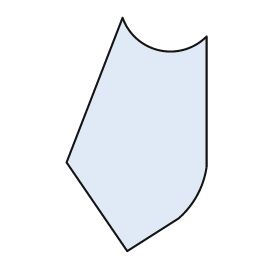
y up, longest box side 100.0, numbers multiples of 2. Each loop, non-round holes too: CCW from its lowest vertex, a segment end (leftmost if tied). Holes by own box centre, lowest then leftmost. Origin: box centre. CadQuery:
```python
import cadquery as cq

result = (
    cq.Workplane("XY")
    .moveTo(-4.0, -50.0)
    .lineTo(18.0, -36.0)
    .threePointArc((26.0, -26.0), (30.0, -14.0))
    .lineTo(30.0, 42.0)
    .threePointArc((10.0, 36.0), (-6.0, 50.0))
    .lineTo(-30.0, -12.0)
    .close()
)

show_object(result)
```